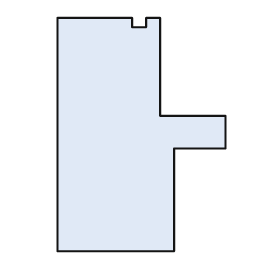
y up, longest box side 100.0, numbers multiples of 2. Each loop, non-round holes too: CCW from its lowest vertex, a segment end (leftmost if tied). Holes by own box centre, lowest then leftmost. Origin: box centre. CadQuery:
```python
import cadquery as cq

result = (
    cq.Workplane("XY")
    .moveTo(-36.0, -50.0)
    .lineTo(14.0, -50.0)
    .lineTo(14.0, -6.0)
    .lineTo(36.0, -6.0)
    .lineTo(36.0, 8.0)
    .lineTo(8.0, 8.0)
    .lineTo(8.0, 50.0)
    .lineTo(2.0, 50.0)
    .lineTo(2.0, 46.0)
    .lineTo(-4.0, 46.0)
    .lineTo(-4.0, 50.0)
    .lineTo(-36.0, 50.0)
    .close()
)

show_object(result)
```